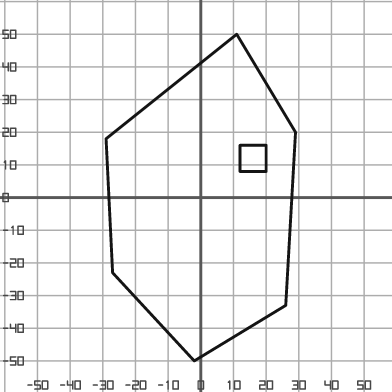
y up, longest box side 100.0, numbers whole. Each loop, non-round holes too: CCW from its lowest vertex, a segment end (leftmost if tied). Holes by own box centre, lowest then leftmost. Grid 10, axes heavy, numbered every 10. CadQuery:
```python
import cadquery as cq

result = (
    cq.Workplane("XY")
    .moveTo(-2.0, -50.0)
    .lineTo(26.0, -33.0)
    .lineTo(29.0, 20.0)
    .lineTo(11.0, 50.0)
    .lineTo(-29.0, 18.0)
    .lineTo(-27.0, -23.0)
    .close()
    .moveTo(12.0, 8.0)
    .lineTo(20.0, 8.0)
    .lineTo(20.0, 16.0)
    .lineTo(12.0, 16.0)
    .close()
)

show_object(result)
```